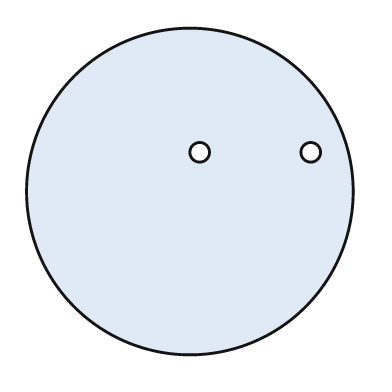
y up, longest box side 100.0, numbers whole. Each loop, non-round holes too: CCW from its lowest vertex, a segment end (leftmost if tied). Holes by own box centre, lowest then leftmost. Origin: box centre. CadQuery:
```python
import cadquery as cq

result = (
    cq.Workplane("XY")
    .moveTo(0.0, 0.0)
    .circle(50.0)
    .moveTo(3.0, 12.0)
    .circle(3.0)
    .moveTo(37.0, 12.0)
    .circle(3.0)
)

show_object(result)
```